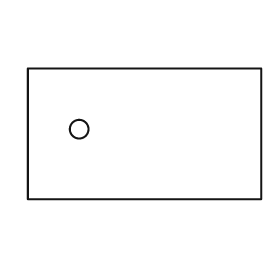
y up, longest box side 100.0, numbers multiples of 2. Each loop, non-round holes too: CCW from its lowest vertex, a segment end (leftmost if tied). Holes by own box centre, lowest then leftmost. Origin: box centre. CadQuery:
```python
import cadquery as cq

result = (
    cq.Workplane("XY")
    .moveTo(-50.0, -28.0)
    .lineTo(50.0, -28.0)
    .lineTo(50.0, 28.0)
    .lineTo(-50.0, 28.0)
    .close()
    .moveTo(-28.0, 2.0)
    .circle(4.0)
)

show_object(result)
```